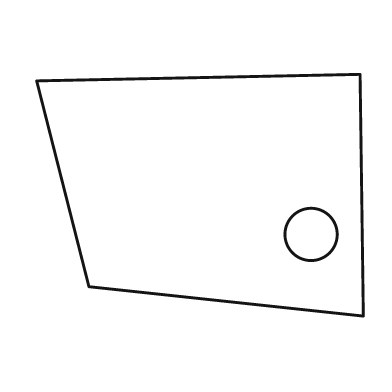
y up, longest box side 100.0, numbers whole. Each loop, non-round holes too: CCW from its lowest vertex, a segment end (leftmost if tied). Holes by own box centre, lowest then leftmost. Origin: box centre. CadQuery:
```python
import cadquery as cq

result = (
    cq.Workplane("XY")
    .moveTo(50.0, -37.0)
    .lineTo(49.0, 37.0)
    .lineTo(-50.0, 35.0)
    .lineTo(-34.0, -28.0)
    .close()
    .moveTo(34.0, -12.0)
    .circle(8.0)
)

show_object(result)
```